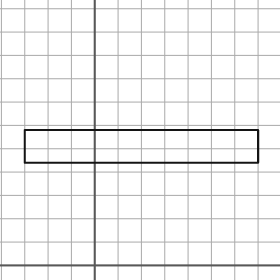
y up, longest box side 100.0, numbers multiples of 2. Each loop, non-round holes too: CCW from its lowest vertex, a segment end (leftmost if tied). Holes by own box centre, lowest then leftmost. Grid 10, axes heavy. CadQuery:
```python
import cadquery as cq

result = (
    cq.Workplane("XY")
    .moveTo(-30.0, 44.0)
    .lineTo(70.0, 44.0)
    .lineTo(70.0, 58.0)
    .lineTo(-30.0, 58.0)
    .close()
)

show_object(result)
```